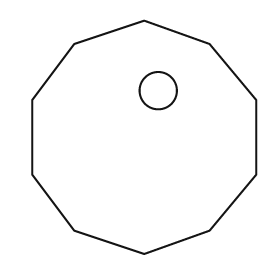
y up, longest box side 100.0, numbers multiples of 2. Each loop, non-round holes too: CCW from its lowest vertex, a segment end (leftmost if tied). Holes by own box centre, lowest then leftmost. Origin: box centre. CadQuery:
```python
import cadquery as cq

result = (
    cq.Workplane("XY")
    .moveTo(0.0, -50.0)
    .lineTo(28.0, -40.0)
    .lineTo(48.0, -16.0)
    .lineTo(48.0, 16.0)
    .lineTo(28.0, 40.0)
    .lineTo(0.0, 50.0)
    .lineTo(-30.0, 40.0)
    .lineTo(-48.0, 16.0)
    .lineTo(-48.0, -16.0)
    .lineTo(-30.0, -40.0)
    .close()
    .moveTo(6.0, 20.0)
    .circle(8.0)
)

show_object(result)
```